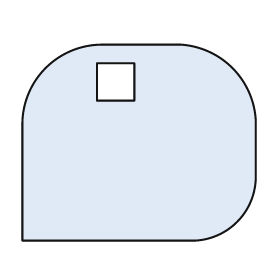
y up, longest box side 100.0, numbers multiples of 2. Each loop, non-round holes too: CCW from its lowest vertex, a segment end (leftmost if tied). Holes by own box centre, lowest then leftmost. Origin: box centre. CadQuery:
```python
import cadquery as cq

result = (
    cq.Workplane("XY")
    .moveTo(-50.0, -42.0)
    .lineTo(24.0, -42.0)
    .threePointArc((42.0, -34.0), (50.0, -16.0))
    .lineTo(50.0, 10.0)
    .threePointArc((40.0, 32.0), (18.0, 42.0))
    .lineTo(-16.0, 42.0)
    .threePointArc((-40.0, 32.0), (-50.0, 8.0))
    .close()
    .moveTo(-18.0, 18.0)
    .lineTo(-2.0, 18.0)
    .lineTo(-2.0, 34.0)
    .lineTo(-18.0, 34.0)
    .close()
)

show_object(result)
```